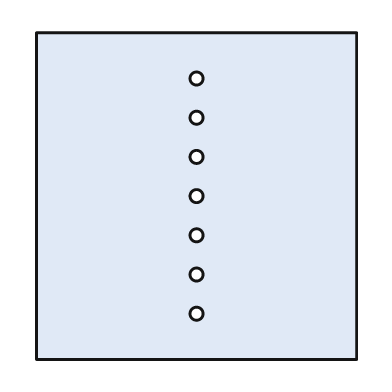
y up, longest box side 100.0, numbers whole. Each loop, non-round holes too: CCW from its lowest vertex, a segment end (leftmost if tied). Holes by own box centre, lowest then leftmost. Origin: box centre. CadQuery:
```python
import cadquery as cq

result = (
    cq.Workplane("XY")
    .moveTo(-49.0, -50.0)
    .lineTo(49.0, -50.0)
    .lineTo(49.0, 50.0)
    .lineTo(-49.0, 50.0)
    .close()
    .moveTo(0.0, -36.0)
    .circle(2.0)
    .moveTo(0.0, -24.0)
    .circle(2.0)
    .moveTo(0.0, -12.0)
    .circle(2.0)
    .moveTo(0.0, 0.0)
    .circle(2.0)
    .moveTo(0.0, 12.0)
    .circle(2.0)
    .moveTo(0.0, 24.0)
    .circle(2.0)
    .moveTo(0.0, 36.0)
    .circle(2.0)
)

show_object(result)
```